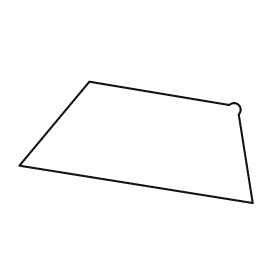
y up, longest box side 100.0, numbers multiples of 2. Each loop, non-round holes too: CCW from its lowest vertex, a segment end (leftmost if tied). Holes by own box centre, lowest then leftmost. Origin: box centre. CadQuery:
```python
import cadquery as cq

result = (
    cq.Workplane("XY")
    .moveTo(50.0, -26.0)
    .lineTo(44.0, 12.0)
    .threePointArc((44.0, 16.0), (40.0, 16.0))
    .lineTo(-20.0, 26.0)
    .lineTo(-50.0, -10.0)
    .close()
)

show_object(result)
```